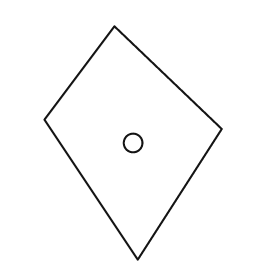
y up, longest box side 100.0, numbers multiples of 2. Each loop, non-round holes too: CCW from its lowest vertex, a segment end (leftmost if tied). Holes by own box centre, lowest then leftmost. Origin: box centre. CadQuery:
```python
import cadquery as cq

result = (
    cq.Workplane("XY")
    .moveTo(2.0, -50.0)
    .lineTo(38.0, 6.0)
    .lineTo(-8.0, 50.0)
    .lineTo(-38.0, 10.0)
    .close()
    .moveTo(0.0, 0.0)
    .circle(4.0)
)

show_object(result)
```